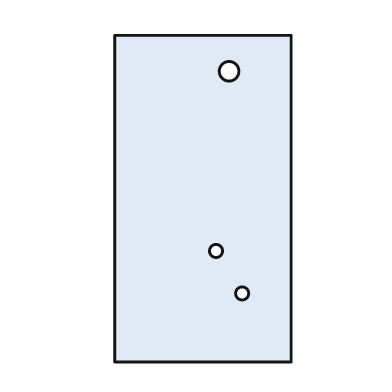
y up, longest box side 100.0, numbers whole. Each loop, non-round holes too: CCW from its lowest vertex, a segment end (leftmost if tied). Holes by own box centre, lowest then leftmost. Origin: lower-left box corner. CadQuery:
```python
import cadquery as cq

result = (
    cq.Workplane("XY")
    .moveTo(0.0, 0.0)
    .lineTo(54.0, 0.0)
    .lineTo(54.0, 100.0)
    .lineTo(0.0, 100.0)
    .close()
    .moveTo(39.0, 21.0)
    .circle(2.0)
    .moveTo(31.0, 34.0)
    .circle(2.0)
    .moveTo(35.0, 89.0)
    .circle(3.0)
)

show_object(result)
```